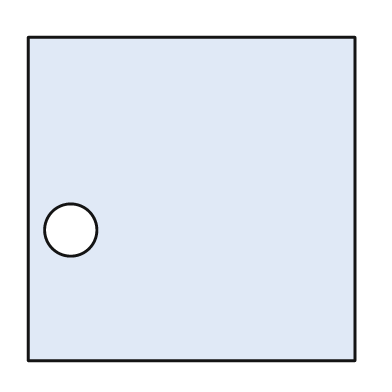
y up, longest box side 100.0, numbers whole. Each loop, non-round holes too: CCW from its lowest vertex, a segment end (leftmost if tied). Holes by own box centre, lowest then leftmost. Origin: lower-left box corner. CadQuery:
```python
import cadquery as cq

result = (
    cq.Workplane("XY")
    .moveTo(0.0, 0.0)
    .lineTo(100.0, 0.0)
    .lineTo(100.0, 99.0)
    .lineTo(0.0, 99.0)
    .close()
    .moveTo(13.0, 40.0)
    .circle(8.0)
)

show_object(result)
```